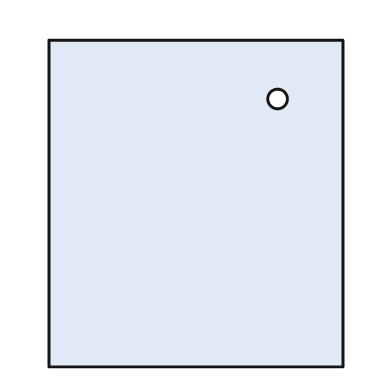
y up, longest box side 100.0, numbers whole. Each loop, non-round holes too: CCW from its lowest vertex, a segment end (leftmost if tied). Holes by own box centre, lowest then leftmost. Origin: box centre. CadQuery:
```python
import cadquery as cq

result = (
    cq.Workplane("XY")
    .moveTo(-45.0, -50.0)
    .lineTo(45.0, -50.0)
    .lineTo(45.0, 50.0)
    .lineTo(-45.0, 50.0)
    .close()
    .moveTo(25.0, 32.0)
    .circle(3.0)
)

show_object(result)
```